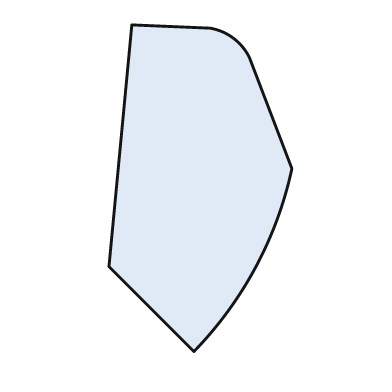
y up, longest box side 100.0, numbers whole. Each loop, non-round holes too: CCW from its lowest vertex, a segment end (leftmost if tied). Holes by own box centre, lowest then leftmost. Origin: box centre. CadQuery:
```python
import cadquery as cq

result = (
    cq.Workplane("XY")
    .moveTo(-2.0, -50.0)
    .threePointArc((17.0, -24.0), (28.0, 6.0))
    .lineTo(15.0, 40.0)
    .threePointArc((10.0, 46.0), (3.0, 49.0))
    .lineTo(-21.0, 50.0)
    .lineTo(-28.0, -24.0)
    .close()
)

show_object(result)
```